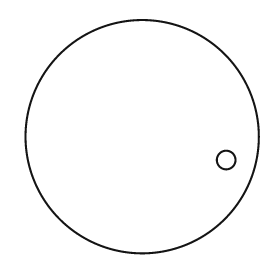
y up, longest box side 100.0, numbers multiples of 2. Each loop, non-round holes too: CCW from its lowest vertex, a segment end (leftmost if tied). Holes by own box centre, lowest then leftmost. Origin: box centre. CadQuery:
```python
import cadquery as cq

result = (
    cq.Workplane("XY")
    .moveTo(0.0, 0.0)
    .circle(50.0)
    .moveTo(36.0, -10.0)
    .circle(4.0)
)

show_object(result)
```